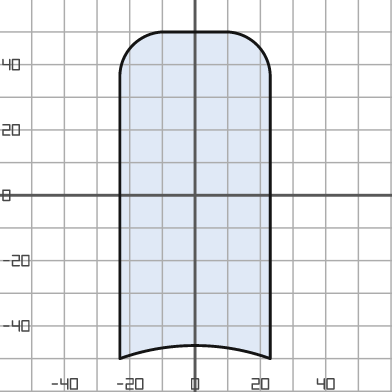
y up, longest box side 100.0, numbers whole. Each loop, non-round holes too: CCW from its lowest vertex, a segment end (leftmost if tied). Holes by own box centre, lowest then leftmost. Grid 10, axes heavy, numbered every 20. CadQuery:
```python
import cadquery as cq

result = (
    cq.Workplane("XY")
    .moveTo(-23.0, -50.0)
    .threePointArc((0.0, -46.0), (23.0, -50.0))
    .lineTo(23.0, 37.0)
    .threePointArc((19.0, 46.0), (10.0, 50.0))
    .lineTo(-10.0, 50.0)
    .threePointArc((-19.0, 46.0), (-23.0, 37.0))
    .close()
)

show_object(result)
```